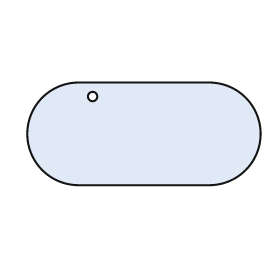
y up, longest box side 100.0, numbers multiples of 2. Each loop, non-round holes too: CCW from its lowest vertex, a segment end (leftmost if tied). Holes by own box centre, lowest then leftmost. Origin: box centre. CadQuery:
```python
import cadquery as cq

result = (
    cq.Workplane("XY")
    .moveTo(-28.0, -22.0)
    .lineTo(28.0, -22.0)
    .threePointArc((50.0, 0.0), (28.0, 22.0))
    .lineTo(-28.0, 22.0)
    .threePointArc((-50.0, 0.0), (-28.0, -22.0))
    .close()
    .moveTo(-22.0, 16.0)
    .circle(2.0)
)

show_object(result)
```